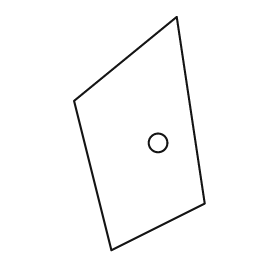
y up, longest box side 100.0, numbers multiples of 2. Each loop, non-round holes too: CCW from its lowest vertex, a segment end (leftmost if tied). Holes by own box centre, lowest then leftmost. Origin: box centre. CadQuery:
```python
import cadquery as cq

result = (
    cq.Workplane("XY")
    .moveTo(-12.0, -50.0)
    .lineTo(28.0, -30.0)
    .lineTo(16.0, 50.0)
    .lineTo(-28.0, 14.0)
    .close()
    .moveTo(8.0, -4.0)
    .circle(4.0)
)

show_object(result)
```